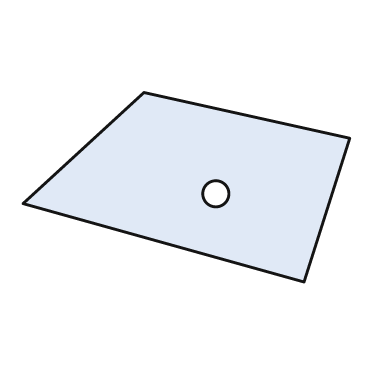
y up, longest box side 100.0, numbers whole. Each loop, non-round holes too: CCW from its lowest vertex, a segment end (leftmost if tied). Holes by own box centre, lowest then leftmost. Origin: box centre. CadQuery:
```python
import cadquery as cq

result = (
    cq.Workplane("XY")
    .moveTo(36.0, -29.0)
    .lineTo(50.0, 15.0)
    .lineTo(-13.0, 29.0)
    .lineTo(-50.0, -5.0)
    .close()
    .moveTo(9.0, -2.0)
    .circle(4.0)
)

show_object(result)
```